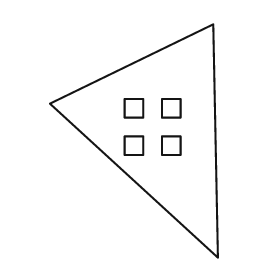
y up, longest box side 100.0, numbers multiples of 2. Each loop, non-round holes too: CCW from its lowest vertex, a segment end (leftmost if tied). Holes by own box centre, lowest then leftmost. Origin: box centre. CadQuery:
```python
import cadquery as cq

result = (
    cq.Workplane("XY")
    .moveTo(36.0, -50.0)
    .lineTo(34.0, 50.0)
    .lineTo(-36.0, 16.0)
    .close()
    .moveTo(-4.0, -6.0)
    .lineTo(4.0, -6.0)
    .lineTo(4.0, 2.0)
    .lineTo(-4.0, 2.0)
    .close()
    .moveTo(12.0, -6.0)
    .lineTo(20.0, -6.0)
    .lineTo(20.0, 2.0)
    .lineTo(12.0, 2.0)
    .close()
    .moveTo(-4.0, 10.0)
    .lineTo(4.0, 10.0)
    .lineTo(4.0, 18.0)
    .lineTo(-4.0, 18.0)
    .close()
    .moveTo(12.0, 10.0)
    .lineTo(20.0, 10.0)
    .lineTo(20.0, 18.0)
    .lineTo(12.0, 18.0)
    .close()
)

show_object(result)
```